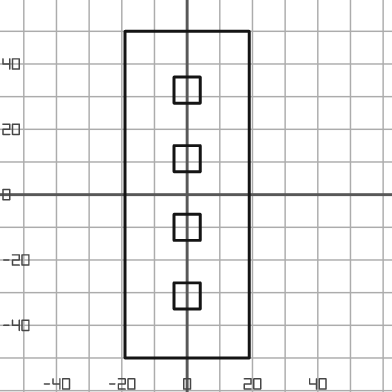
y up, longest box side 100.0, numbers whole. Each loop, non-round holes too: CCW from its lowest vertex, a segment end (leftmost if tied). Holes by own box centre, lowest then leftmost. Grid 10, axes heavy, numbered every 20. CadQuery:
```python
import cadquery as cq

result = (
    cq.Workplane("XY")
    .moveTo(-19.0, -50.0)
    .lineTo(19.0, -50.0)
    .lineTo(19.0, 50.0)
    .lineTo(-19.0, 50.0)
    .close()
    .moveTo(-4.0, -35.0)
    .lineTo(4.0, -35.0)
    .lineTo(4.0, -27.0)
    .lineTo(-4.0, -27.0)
    .close()
    .moveTo(-4.0, -14.0)
    .lineTo(4.0, -14.0)
    .lineTo(4.0, -6.0)
    .lineTo(-4.0, -6.0)
    .close()
    .moveTo(-4.0, 7.0)
    .lineTo(4.0, 7.0)
    .lineTo(4.0, 15.0)
    .lineTo(-4.0, 15.0)
    .close()
    .moveTo(-4.0, 28.0)
    .lineTo(4.0, 28.0)
    .lineTo(4.0, 36.0)
    .lineTo(-4.0, 36.0)
    .close()
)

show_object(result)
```